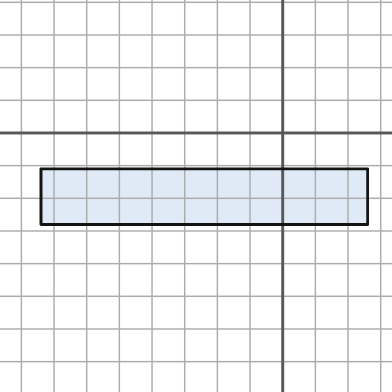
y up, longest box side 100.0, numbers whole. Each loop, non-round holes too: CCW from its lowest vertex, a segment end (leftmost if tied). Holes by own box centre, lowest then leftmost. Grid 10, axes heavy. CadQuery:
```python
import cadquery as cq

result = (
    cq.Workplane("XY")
    .moveTo(-74.0, -28.0)
    .lineTo(26.0, -28.0)
    .lineTo(26.0, -11.0)
    .lineTo(-74.0, -11.0)
    .close()
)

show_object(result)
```